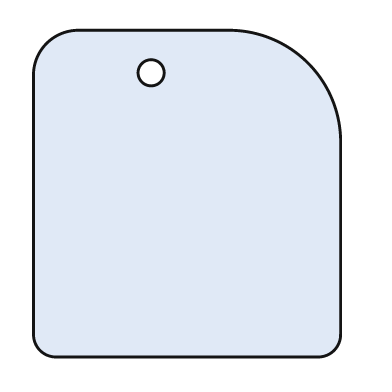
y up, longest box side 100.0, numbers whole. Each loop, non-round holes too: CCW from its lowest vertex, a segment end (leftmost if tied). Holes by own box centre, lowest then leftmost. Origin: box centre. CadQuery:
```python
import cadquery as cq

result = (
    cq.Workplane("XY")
    .moveTo(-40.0, -50.0)
    .lineTo(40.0, -50.0)
    .threePointArc((45.0, -48.0), (47.0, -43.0))
    .lineTo(47.0, 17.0)
    .threePointArc((37.0, 40.0), (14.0, 50.0))
    .lineTo(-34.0, 50.0)
    .threePointArc((-43.0, 46.0), (-47.0, 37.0))
    .lineTo(-47.0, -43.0)
    .threePointArc((-45.0, -48.0), (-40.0, -50.0))
    .close()
    .moveTo(-11.0, 37.0)
    .circle(4.0)
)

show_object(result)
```